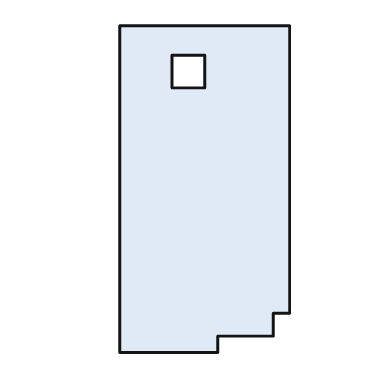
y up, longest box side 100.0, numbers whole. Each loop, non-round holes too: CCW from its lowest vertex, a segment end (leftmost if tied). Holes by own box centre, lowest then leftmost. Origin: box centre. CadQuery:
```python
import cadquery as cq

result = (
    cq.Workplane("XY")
    .moveTo(-26.0, -50.0)
    .lineTo(4.0, -50.0)
    .lineTo(4.0, -45.0)
    .lineTo(21.0, -45.0)
    .lineTo(21.0, -38.0)
    .lineTo(26.0, -38.0)
    .lineTo(26.0, 50.0)
    .lineTo(-26.0, 50.0)
    .close()
    .moveTo(-10.0, 31.0)
    .lineTo(0.0, 31.0)
    .lineTo(0.0, 41.0)
    .lineTo(-10.0, 41.0)
    .close()
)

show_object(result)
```